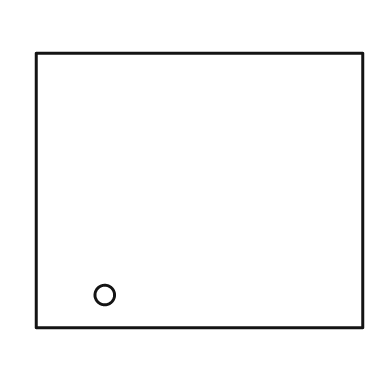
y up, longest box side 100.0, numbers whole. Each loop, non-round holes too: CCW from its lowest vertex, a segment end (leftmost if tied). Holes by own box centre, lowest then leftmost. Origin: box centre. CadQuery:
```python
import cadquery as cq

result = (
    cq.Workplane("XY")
    .moveTo(-50.0, -42.0)
    .lineTo(50.0, -42.0)
    .lineTo(50.0, 42.0)
    .lineTo(-50.0, 42.0)
    .close()
    .moveTo(-29.0, -32.0)
    .circle(3.0)
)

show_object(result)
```